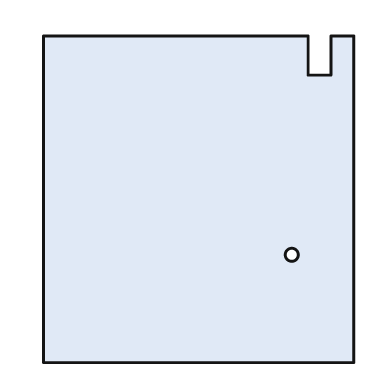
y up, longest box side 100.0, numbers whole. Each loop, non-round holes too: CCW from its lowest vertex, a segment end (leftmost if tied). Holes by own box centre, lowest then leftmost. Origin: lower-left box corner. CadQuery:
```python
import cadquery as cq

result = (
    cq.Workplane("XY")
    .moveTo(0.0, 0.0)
    .lineTo(95.0, 0.0)
    .lineTo(95.0, 100.0)
    .lineTo(88.0, 100.0)
    .lineTo(88.0, 88.0)
    .lineTo(81.0, 88.0)
    .lineTo(81.0, 100.0)
    .lineTo(0.0, 100.0)
    .close()
    .moveTo(76.0, 33.0)
    .circle(2.0)
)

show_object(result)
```